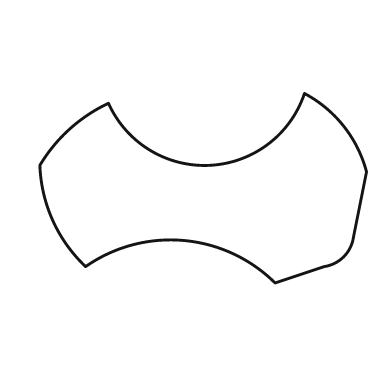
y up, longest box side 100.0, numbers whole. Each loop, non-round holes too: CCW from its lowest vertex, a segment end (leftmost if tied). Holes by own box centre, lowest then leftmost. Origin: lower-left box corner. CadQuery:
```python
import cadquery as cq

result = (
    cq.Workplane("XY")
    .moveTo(72.0, 0.0)
    .lineTo(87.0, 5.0)
    .threePointArc((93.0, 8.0), (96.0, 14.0))
    .lineTo(100.0, 34.0)
    .threePointArc((93.0, 48.0), (81.0, 58.0))
    .threePointArc((52.0, 36.0), (21.0, 55.0))
    .threePointArc((9.0, 47.0), (0.0, 36.0))
    .threePointArc((4.0, 19.0), (14.0, 5.0))
    .threePointArc((44.0, 13.0), (72.0, 0.0))
    .close()
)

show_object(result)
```